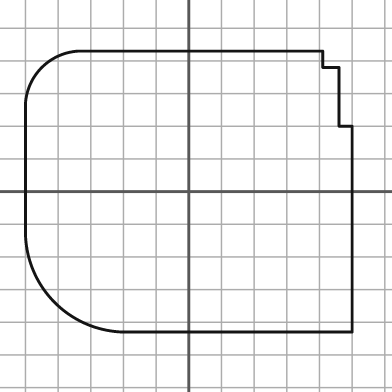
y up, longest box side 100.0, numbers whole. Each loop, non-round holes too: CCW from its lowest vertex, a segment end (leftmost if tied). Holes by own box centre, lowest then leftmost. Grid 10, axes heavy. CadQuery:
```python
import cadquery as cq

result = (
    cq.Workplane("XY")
    .moveTo(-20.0, -43.0)
    .lineTo(50.0, -43.0)
    .lineTo(50.0, 20.0)
    .lineTo(46.0, 20.0)
    .lineTo(46.0, 38.0)
    .lineTo(41.0, 38.0)
    .lineTo(41.0, 43.0)
    .lineTo(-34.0, 43.0)
    .threePointArc((-45.0, 38.0), (-50.0, 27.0))
    .lineTo(-50.0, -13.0)
    .threePointArc((-41.0, -34.0), (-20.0, -43.0))
    .close()
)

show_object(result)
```